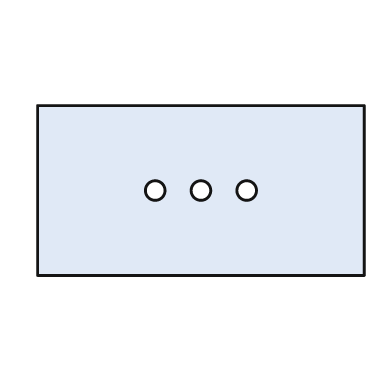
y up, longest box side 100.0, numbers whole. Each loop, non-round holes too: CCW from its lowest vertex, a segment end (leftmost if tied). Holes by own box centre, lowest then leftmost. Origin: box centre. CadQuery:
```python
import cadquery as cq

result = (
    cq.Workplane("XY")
    .moveTo(-50.0, -26.0)
    .lineTo(50.0, -26.0)
    .lineTo(50.0, 26.0)
    .lineTo(-50.0, 26.0)
    .close()
    .moveTo(-14.0, 0.0)
    .circle(3.0)
    .moveTo(0.0, 0.0)
    .circle(3.0)
    .moveTo(14.0, 0.0)
    .circle(3.0)
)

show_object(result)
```